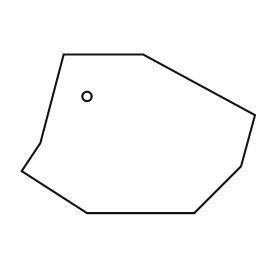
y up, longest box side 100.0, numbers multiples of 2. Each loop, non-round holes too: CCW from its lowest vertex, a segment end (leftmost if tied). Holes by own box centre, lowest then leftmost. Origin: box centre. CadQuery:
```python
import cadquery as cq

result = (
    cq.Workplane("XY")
    .moveTo(-22.0, -34.0)
    .lineTo(24.0, -34.0)
    .lineTo(44.0, -14.0)
    .lineTo(50.0, 8.0)
    .lineTo(2.0, 34.0)
    .lineTo(-32.0, 34.0)
    .lineTo(-42.0, -4.0)
    .lineTo(-50.0, -16.0)
    .close()
    .moveTo(-22.0, 16.0)
    .circle(2.0)
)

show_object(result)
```